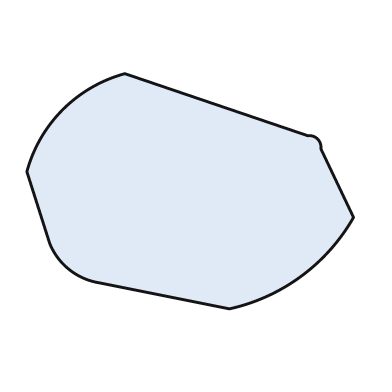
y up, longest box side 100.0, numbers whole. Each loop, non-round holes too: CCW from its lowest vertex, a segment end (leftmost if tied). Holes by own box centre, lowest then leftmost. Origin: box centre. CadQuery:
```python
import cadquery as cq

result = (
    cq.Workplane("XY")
    .moveTo(12.0, -36.0)
    .threePointArc((34.0, -26.0), (50.0, -8.0))
    .lineTo(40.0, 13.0)
    .threePointArc((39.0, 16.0), (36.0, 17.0))
    .lineTo(-20.0, 36.0)
    .threePointArc((-39.0, 25.0), (-50.0, 6.0))
    .lineTo(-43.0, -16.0)
    .threePointArc((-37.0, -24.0), (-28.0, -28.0))
    .close()
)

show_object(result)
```